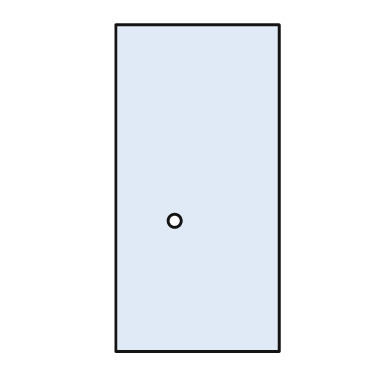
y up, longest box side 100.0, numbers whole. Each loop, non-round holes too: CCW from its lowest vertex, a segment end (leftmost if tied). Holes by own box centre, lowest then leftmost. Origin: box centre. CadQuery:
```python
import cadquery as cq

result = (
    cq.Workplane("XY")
    .moveTo(-25.0, -50.0)
    .lineTo(25.0, -50.0)
    .lineTo(25.0, 50.0)
    .lineTo(-25.0, 50.0)
    .close()
    .moveTo(-7.0, -10.0)
    .circle(2.0)
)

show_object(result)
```